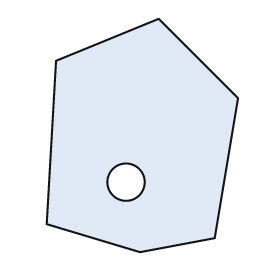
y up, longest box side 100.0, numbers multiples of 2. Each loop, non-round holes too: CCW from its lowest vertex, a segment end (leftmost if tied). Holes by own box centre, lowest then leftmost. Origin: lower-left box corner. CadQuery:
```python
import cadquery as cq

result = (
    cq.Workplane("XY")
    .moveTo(40.0, 0.0)
    .lineTo(72.0, 6.0)
    .lineTo(82.0, 66.0)
    .lineTo(48.0, 100.0)
    .lineTo(4.0, 82.0)
    .lineTo(0.0, 12.0)
    .close()
    .moveTo(34.0, 30.0)
    .circle(8.0)
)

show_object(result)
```